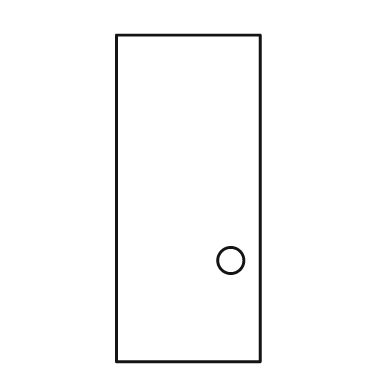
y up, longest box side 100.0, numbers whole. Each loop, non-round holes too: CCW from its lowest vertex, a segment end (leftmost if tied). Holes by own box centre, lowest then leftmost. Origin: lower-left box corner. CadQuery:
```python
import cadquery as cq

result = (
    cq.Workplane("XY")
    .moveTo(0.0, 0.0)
    .lineTo(44.0, 0.0)
    .lineTo(44.0, 100.0)
    .lineTo(0.0, 100.0)
    .close()
    .moveTo(35.0, 31.0)
    .circle(4.0)
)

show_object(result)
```